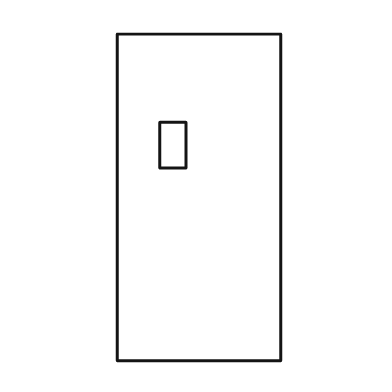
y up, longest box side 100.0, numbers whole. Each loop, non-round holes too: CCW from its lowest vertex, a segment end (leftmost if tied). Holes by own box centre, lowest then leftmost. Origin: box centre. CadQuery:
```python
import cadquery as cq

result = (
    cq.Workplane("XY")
    .moveTo(-25.0, -50.0)
    .lineTo(25.0, -50.0)
    .lineTo(25.0, 50.0)
    .lineTo(-25.0, 50.0)
    .close()
    .moveTo(-12.0, 9.0)
    .lineTo(-4.0, 9.0)
    .lineTo(-4.0, 23.0)
    .lineTo(-12.0, 23.0)
    .close()
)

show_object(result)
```